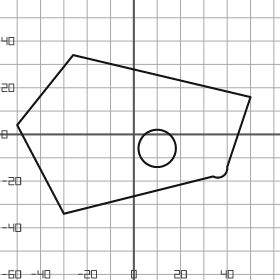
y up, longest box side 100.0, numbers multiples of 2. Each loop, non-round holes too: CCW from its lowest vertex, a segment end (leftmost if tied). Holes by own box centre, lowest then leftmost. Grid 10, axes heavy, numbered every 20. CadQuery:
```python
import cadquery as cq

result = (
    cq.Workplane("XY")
    .moveTo(-30.0, -34.0)
    .lineTo(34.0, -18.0)
    .threePointArc((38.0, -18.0), (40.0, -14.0))
    .lineTo(50.0, 16.0)
    .lineTo(-26.0, 34.0)
    .lineTo(-50.0, 4.0)
    .close()
    .moveTo(10.0, -6.0)
    .circle(8.0)
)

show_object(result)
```